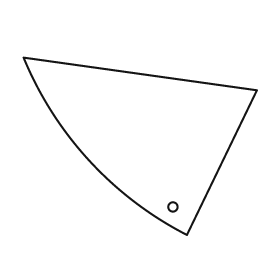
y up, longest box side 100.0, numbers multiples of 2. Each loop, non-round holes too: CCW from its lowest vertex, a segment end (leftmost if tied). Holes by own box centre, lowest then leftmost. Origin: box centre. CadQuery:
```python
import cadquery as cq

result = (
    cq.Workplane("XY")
    .moveTo(20.0, -38.0)
    .lineTo(50.0, 24.0)
    .lineTo(-50.0, 38.0)
    .threePointArc((-22.0, -6.0), (20.0, -38.0))
    .close()
    .moveTo(14.0, -26.0)
    .circle(2.0)
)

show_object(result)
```